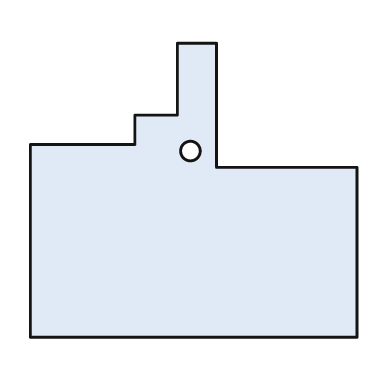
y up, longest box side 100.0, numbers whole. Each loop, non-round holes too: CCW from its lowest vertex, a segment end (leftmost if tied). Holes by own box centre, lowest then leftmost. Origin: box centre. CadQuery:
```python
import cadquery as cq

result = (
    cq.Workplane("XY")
    .moveTo(-50.0, -45.0)
    .lineTo(50.0, -45.0)
    .lineTo(50.0, 7.0)
    .lineTo(7.0, 7.0)
    .lineTo(7.0, 45.0)
    .lineTo(-5.0, 45.0)
    .lineTo(-5.0, 23.0)
    .lineTo(-18.0, 23.0)
    .lineTo(-18.0, 14.0)
    .lineTo(-50.0, 14.0)
    .close()
    .moveTo(-1.0, 12.0)
    .circle(3.0)
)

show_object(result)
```